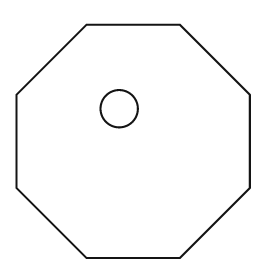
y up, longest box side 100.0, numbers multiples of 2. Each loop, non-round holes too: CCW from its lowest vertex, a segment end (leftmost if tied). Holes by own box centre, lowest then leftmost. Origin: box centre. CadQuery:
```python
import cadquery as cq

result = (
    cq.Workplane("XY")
    .moveTo(-20.0, -50.0)
    .lineTo(20.0, -50.0)
    .lineTo(50.0, -20.0)
    .lineTo(50.0, 20.0)
    .lineTo(20.0, 50.0)
    .lineTo(-20.0, 50.0)
    .lineTo(-50.0, 20.0)
    .lineTo(-50.0, -20.0)
    .close()
    .moveTo(-6.0, 14.0)
    .circle(8.0)
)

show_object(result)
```